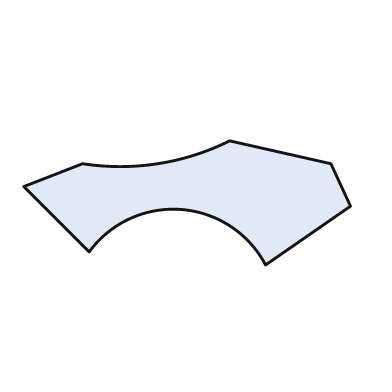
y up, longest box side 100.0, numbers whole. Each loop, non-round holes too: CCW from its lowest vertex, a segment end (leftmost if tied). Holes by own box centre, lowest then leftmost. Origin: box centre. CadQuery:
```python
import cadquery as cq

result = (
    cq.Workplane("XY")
    .moveTo(24.0, -19.0)
    .lineTo(50.0, -1.0)
    .lineTo(44.0, 12.0)
    .lineTo(13.0, 19.0)
    .threePointArc((-9.0, 12.0), (-32.0, 12.0))
    .lineTo(-50.0, 5.0)
    .lineTo(-30.0, -15.0)
    .threePointArc((-2.0, -2.0), (24.0, -19.0))
    .close()
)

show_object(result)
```